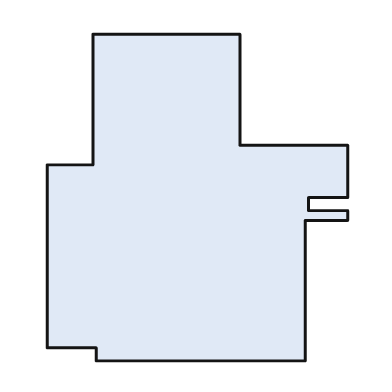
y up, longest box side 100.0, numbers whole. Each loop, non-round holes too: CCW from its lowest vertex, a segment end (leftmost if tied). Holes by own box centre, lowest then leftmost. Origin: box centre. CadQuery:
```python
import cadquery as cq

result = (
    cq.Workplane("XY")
    .moveTo(-31.0, -50.0)
    .lineTo(33.0, -50.0)
    .lineTo(33.0, -7.0)
    .lineTo(46.0, -7.0)
    .lineTo(46.0, -4.0)
    .lineTo(34.0, -4.0)
    .lineTo(34.0, 0.0)
    .lineTo(46.0, 0.0)
    .lineTo(46.0, 16.0)
    .lineTo(13.0, 16.0)
    .lineTo(13.0, 50.0)
    .lineTo(-32.0, 50.0)
    .lineTo(-32.0, 10.0)
    .lineTo(-46.0, 10.0)
    .lineTo(-46.0, -46.0)
    .lineTo(-31.0, -46.0)
    .close()
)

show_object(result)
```